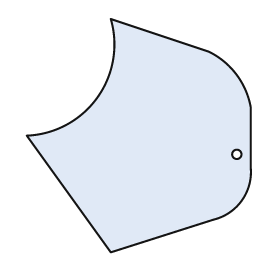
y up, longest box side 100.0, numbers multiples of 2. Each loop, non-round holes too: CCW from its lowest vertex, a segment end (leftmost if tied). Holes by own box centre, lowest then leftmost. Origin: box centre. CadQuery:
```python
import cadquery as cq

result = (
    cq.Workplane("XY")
    .moveTo(-12.0, -50.0)
    .lineTo(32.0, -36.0)
    .threePointArc((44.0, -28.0), (48.0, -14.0))
    .lineTo(48.0, 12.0)
    .threePointArc((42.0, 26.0), (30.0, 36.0))
    .lineTo(-12.0, 50.0)
    .threePointArc((-18.0, 16.0), (-48.0, 0.0))
    .close()
    .moveTo(42.0, -8.0)
    .circle(2.0)
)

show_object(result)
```